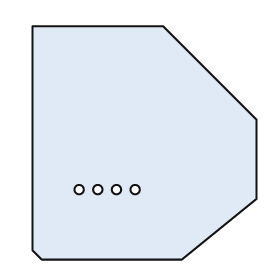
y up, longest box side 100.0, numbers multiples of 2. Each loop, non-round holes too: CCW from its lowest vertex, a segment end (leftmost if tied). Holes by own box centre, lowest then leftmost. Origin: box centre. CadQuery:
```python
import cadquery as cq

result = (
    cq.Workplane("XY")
    .moveTo(-44.0, -50.0)
    .lineTo(16.0, -50.0)
    .lineTo(48.0, -24.0)
    .lineTo(48.0, 10.0)
    .lineTo(8.0, 50.0)
    .lineTo(-48.0, 50.0)
    .lineTo(-48.0, -46.0)
    .close()
    .moveTo(-28.0, -20.0)
    .circle(2.0)
    .moveTo(-20.0, -20.0)
    .circle(2.0)
    .moveTo(-12.0, -20.0)
    .circle(2.0)
    .moveTo(-4.0, -20.0)
    .circle(2.0)
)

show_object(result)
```